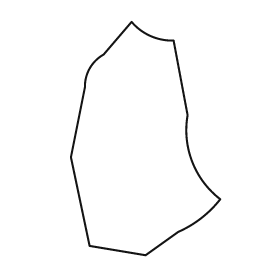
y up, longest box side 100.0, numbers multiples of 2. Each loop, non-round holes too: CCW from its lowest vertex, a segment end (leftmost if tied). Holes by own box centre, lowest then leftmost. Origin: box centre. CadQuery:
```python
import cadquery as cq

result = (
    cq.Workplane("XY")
    .moveTo(0.0, -50.0)
    .lineTo(14.0, -40.0)
    .threePointArc((24.0, -34.0), (32.0, -26.0))
    .threePointArc((20.0, -10.0), (18.0, 10.0))
    .lineTo(12.0, 42.0)
    .threePointArc((2.0, 44.0), (-6.0, 50.0))
    .lineTo(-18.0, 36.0)
    .threePointArc((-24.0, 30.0), (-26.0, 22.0))
    .lineTo(-32.0, -8.0)
    .lineTo(-24.0, -46.0)
    .close()
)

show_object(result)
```